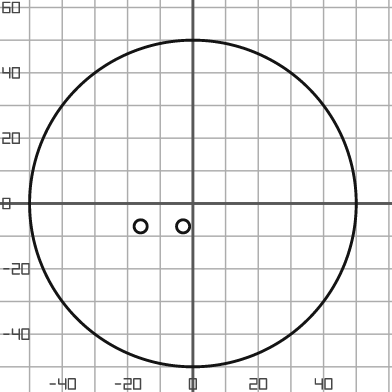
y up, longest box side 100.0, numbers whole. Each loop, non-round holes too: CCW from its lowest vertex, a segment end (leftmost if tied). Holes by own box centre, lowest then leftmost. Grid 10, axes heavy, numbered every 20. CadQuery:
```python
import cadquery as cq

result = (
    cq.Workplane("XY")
    .moveTo(0.0, 0.0)
    .circle(50.0)
    .moveTo(-16.0, -7.0)
    .circle(2.0)
    .moveTo(-3.0, -7.0)
    .circle(2.0)
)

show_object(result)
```